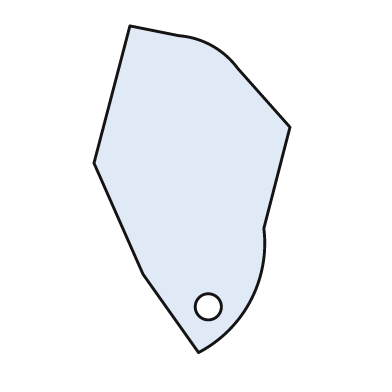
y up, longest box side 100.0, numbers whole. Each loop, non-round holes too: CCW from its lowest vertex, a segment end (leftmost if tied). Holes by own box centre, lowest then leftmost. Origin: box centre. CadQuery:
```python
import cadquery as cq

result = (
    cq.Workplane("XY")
    .moveTo(2.0, -50.0)
    .threePointArc((18.0, -34.0), (22.0, -12.0))
    .lineTo(30.0, 19.0)
    .lineTo(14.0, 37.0)
    .threePointArc((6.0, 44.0), (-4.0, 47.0))
    .lineTo(-19.0, 50.0)
    .lineTo(-30.0, 8.0)
    .lineTo(-15.0, -26.0)
    .close()
    .moveTo(5.0, -36.0)
    .circle(4.0)
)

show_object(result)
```